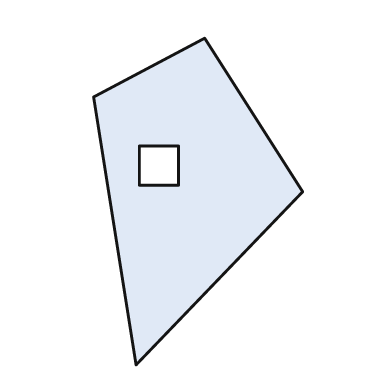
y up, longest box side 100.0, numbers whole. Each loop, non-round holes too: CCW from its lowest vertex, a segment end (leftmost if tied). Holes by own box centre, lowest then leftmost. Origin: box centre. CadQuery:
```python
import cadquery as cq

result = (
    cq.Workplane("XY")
    .moveTo(-19.0, -50.0)
    .lineTo(32.0, 3.0)
    .lineTo(2.0, 50.0)
    .lineTo(-32.0, 32.0)
    .close()
    .moveTo(-18.0, 5.0)
    .lineTo(-6.0, 5.0)
    .lineTo(-6.0, 17.0)
    .lineTo(-18.0, 17.0)
    .close()
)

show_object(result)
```